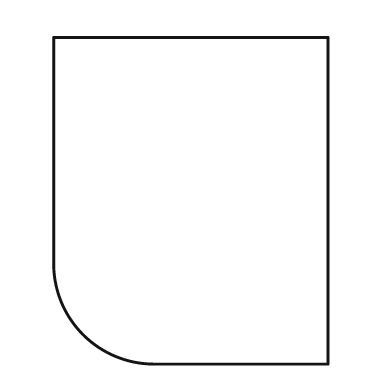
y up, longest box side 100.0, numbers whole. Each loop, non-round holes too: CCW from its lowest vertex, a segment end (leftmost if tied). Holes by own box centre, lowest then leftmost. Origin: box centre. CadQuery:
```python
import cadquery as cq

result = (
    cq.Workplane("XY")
    .moveTo(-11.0, -50.0)
    .lineTo(42.0, -50.0)
    .lineTo(42.0, 50.0)
    .lineTo(-42.0, 50.0)
    .lineTo(-42.0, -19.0)
    .threePointArc((-33.0, -41.0), (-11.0, -50.0))
    .close()
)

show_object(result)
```